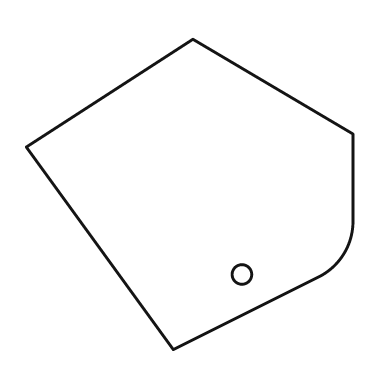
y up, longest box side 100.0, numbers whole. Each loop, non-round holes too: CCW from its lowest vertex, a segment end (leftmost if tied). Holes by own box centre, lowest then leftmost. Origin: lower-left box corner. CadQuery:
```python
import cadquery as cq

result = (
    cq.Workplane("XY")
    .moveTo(45.0, 0.0)
    .lineTo(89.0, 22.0)
    .threePointArc((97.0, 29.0), (100.0, 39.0))
    .lineTo(100.0, 66.0)
    .lineTo(51.0, 95.0)
    .lineTo(0.0, 62.0)
    .close()
    .moveTo(66.0, 23.0)
    .circle(3.0)
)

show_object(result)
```